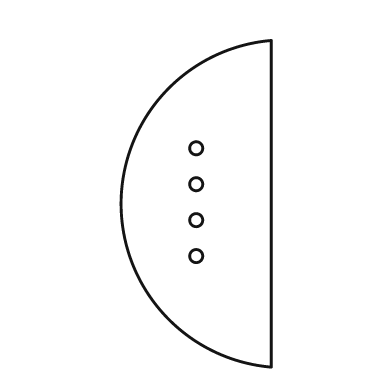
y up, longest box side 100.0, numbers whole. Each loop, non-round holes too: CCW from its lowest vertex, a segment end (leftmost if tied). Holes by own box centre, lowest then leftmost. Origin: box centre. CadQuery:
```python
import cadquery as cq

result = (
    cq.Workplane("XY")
    .moveTo(23.0, -50.0)
    .lineTo(23.0, 50.0)
    .threePointArc((-23.0, 0.0), (23.0, -50.0))
    .close()
    .moveTo(0.0, -16.0)
    .circle(2.0)
    .moveTo(0.0, -5.0)
    .circle(2.0)
    .moveTo(0.0, 6.0)
    .circle(2.0)
    .moveTo(0.0, 17.0)
    .circle(2.0)
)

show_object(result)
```